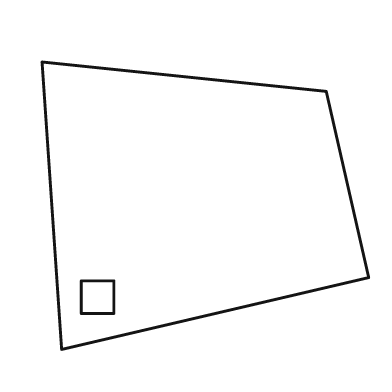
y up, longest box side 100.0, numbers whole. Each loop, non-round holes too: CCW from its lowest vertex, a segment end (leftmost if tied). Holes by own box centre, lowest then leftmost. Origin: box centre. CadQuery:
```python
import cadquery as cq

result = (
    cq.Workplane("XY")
    .moveTo(-44.0, -44.0)
    .lineTo(50.0, -22.0)
    .lineTo(37.0, 35.0)
    .lineTo(-50.0, 44.0)
    .close()
    .moveTo(-38.0, -33.0)
    .lineTo(-28.0, -33.0)
    .lineTo(-28.0, -23.0)
    .lineTo(-38.0, -23.0)
    .close()
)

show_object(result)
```